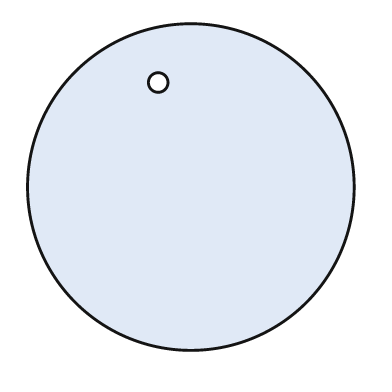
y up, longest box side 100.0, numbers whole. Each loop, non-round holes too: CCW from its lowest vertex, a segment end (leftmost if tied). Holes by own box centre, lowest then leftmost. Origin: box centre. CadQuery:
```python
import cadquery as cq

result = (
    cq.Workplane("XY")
    .moveTo(0.0, 0.0)
    .circle(50.0)
    .moveTo(-10.0, 32.0)
    .circle(3.0)
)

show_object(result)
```